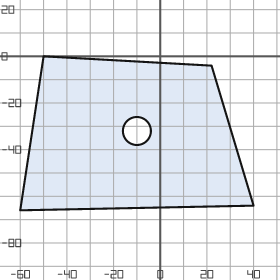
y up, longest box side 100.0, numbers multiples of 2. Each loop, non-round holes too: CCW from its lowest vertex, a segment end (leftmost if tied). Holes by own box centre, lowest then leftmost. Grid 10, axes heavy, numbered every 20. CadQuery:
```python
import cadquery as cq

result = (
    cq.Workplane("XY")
    .moveTo(-60.0, -66.0)
    .lineTo(40.0, -64.0)
    .lineTo(22.0, -4.0)
    .lineTo(-50.0, 0.0)
    .close()
    .moveTo(-10.0, -32.0)
    .circle(6.0)
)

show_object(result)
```